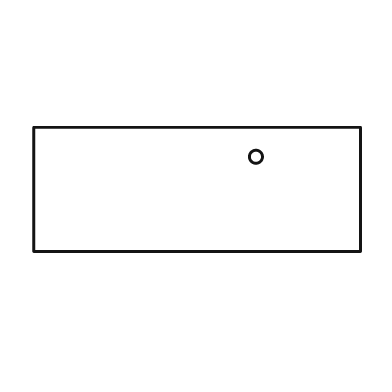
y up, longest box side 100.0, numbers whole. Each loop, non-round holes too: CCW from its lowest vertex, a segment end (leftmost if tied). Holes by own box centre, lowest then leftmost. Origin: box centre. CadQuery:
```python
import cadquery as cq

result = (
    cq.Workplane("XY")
    .moveTo(-50.0, -19.0)
    .lineTo(50.0, -19.0)
    .lineTo(50.0, 19.0)
    .lineTo(-50.0, 19.0)
    .close()
    .moveTo(18.0, 10.0)
    .circle(2.0)
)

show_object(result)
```